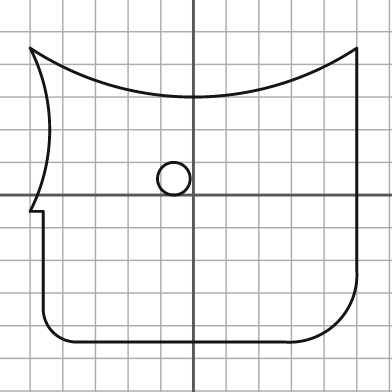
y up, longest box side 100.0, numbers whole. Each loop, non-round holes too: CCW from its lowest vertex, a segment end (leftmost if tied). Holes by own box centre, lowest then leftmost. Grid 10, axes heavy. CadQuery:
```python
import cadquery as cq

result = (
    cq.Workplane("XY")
    .moveTo(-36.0, -45.0)
    .lineTo(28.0, -45.0)
    .threePointArc((44.0, -39.0), (50.0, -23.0))
    .lineTo(50.0, 45.0)
    .threePointArc((0.0, 30.0), (-50.0, 45.0))
    .threePointArc((-44.0, 20.0), (-50.0, -5.0))
    .lineTo(-46.0, -5.0)
    .lineTo(-46.0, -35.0)
    .threePointArc((-43.0, -42.0), (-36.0, -45.0))
    .close()
    .moveTo(-6.0, 5.0)
    .circle(5.0)
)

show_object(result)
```